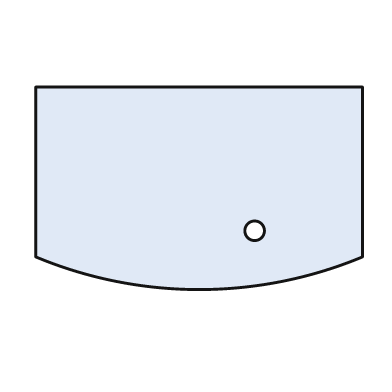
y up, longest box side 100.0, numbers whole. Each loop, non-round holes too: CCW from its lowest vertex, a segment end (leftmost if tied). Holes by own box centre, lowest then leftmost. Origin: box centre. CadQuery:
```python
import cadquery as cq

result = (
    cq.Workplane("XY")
    .moveTo(-50.0, -21.0)
    .threePointArc((0.0, -31.0), (50.0, -21.0))
    .lineTo(50.0, 31.0)
    .lineTo(-50.0, 31.0)
    .close()
    .moveTo(17.0, -13.0)
    .circle(3.0)
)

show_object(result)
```